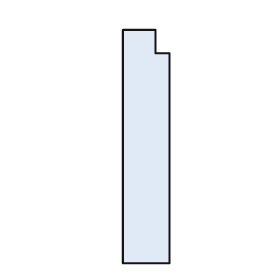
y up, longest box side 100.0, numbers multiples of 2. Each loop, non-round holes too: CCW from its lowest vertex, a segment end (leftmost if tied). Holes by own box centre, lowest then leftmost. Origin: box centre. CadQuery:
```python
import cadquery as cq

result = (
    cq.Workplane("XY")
    .moveTo(-10.0, -50.0)
    .lineTo(10.0, -50.0)
    .lineTo(10.0, 40.0)
    .lineTo(4.0, 40.0)
    .lineTo(4.0, 50.0)
    .lineTo(-10.0, 50.0)
    .close()
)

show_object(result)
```